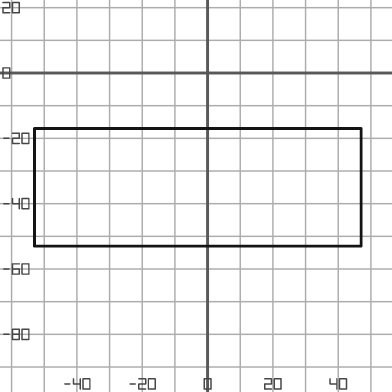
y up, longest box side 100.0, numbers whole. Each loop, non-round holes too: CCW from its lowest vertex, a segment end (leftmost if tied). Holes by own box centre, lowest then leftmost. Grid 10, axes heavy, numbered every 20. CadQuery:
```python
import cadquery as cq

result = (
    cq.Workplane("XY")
    .moveTo(-53.0, -53.0)
    .lineTo(47.0, -53.0)
    .lineTo(47.0, -17.0)
    .lineTo(-53.0, -17.0)
    .close()
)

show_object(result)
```